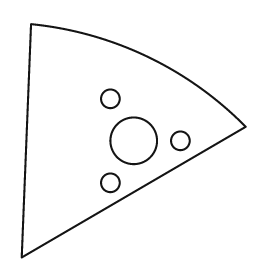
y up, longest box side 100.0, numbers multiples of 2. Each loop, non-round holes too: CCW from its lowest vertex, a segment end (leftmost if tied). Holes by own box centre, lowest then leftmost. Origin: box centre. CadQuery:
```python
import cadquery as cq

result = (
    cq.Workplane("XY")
    .moveTo(-48.0, -50.0)
    .lineTo(48.0, 6.0)
    .threePointArc((6.0, 36.0), (-44.0, 50.0))
    .close()
    .moveTo(-10.0, -18.0)
    .circle(4.0)
    .moveTo(0.0, 0.0)
    .circle(10.0)
    .moveTo(20.0, 0.0)
    .circle(4.0)
    .moveTo(-10.0, 18.0)
    .circle(4.0)
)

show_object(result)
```